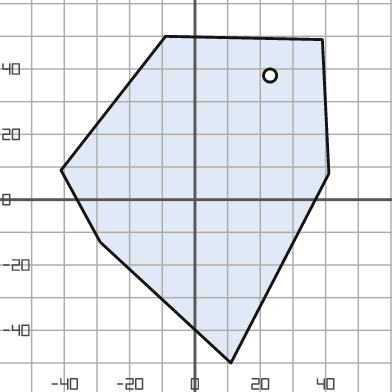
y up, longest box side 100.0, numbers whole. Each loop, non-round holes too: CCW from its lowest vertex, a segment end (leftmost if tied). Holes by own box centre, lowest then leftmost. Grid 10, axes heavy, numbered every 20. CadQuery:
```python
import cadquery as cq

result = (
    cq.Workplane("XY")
    .moveTo(11.0, -50.0)
    .lineTo(41.0, 8.0)
    .lineTo(39.0, 49.0)
    .lineTo(-9.0, 50.0)
    .lineTo(-41.0, 9.0)
    .lineTo(-29.0, -13.0)
    .close()
    .moveTo(23.0, 38.0)
    .circle(2.0)
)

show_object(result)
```